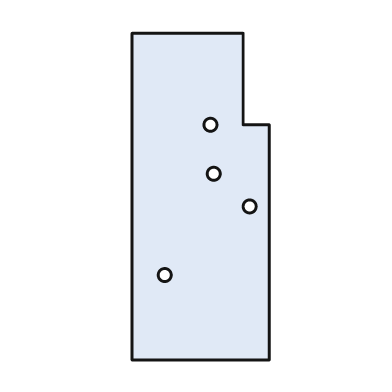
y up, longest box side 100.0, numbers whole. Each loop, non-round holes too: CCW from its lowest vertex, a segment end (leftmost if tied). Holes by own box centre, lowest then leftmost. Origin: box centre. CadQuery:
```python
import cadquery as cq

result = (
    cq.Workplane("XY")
    .moveTo(-21.0, -50.0)
    .lineTo(21.0, -50.0)
    .lineTo(21.0, 22.0)
    .lineTo(13.0, 22.0)
    .lineTo(13.0, 50.0)
    .lineTo(-21.0, 50.0)
    .close()
    .moveTo(-11.0, -24.0)
    .circle(2.0)
    .moveTo(15.0, -3.0)
    .circle(2.0)
    .moveTo(4.0, 7.0)
    .circle(2.0)
    .moveTo(3.0, 22.0)
    .circle(2.0)
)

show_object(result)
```